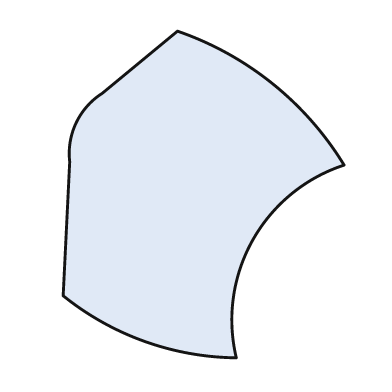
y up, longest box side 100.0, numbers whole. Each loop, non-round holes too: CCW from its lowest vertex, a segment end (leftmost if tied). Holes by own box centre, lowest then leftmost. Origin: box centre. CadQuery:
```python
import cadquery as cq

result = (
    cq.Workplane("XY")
    .moveTo(10.0, -50.0)
    .threePointArc((15.0, -14.0), (43.0, 9.0))
    .threePointArc((21.0, 34.0), (-8.0, 50.0))
    .lineTo(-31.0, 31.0)
    .threePointArc((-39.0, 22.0), (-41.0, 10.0))
    .lineTo(-43.0, -31.0)
    .threePointArc((-18.0, -45.0), (10.0, -50.0))
    .close()
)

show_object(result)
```